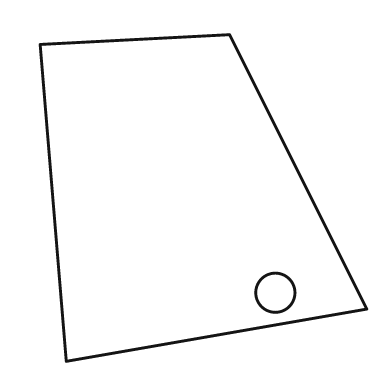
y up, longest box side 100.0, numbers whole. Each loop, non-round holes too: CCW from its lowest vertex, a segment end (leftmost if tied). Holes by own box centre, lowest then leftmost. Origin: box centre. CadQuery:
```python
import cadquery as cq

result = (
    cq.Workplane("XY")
    .moveTo(-42.0, -50.0)
    .lineTo(50.0, -34.0)
    .lineTo(8.0, 50.0)
    .lineTo(-50.0, 47.0)
    .close()
    .moveTo(22.0, -29.0)
    .circle(6.0)
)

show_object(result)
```